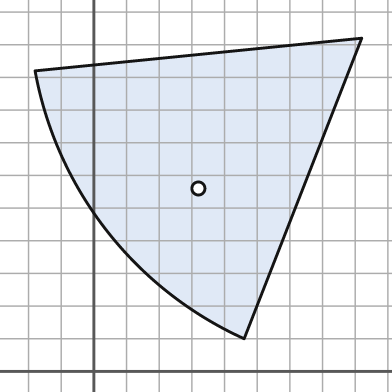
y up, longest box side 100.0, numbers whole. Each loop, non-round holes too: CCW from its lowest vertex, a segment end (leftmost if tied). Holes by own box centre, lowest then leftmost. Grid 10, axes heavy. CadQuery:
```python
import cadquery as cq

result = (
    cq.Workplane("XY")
    .moveTo(46.0, 10.0)
    .lineTo(82.0, 102.0)
    .lineTo(-18.0, 92.0)
    .threePointArc((4.0, 43.0), (46.0, 10.0))
    .close()
    .moveTo(32.0, 56.0)
    .circle(2.0)
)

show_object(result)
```